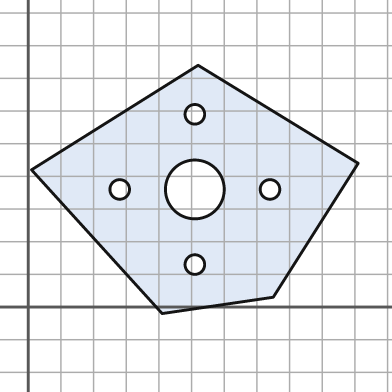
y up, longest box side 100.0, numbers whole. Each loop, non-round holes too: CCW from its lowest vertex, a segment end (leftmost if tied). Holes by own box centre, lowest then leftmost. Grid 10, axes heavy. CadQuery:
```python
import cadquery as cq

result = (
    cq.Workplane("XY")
    .moveTo(41.0, -2.0)
    .lineTo(75.0, 3.0)
    .lineTo(101.0, 44.0)
    .lineTo(52.0, 74.0)
    .lineTo(1.0, 42.0)
    .close()
    .moveTo(51.0, 13.0)
    .circle(3.0)
    .moveTo(28.0, 36.0)
    .circle(3.0)
    .moveTo(51.0, 36.0)
    .circle(9.0)
    .moveTo(74.0, 36.0)
    .circle(3.0)
    .moveTo(51.0, 59.0)
    .circle(3.0)
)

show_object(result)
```